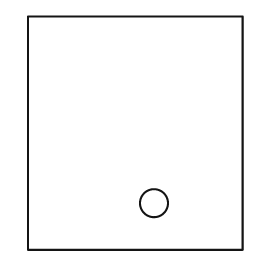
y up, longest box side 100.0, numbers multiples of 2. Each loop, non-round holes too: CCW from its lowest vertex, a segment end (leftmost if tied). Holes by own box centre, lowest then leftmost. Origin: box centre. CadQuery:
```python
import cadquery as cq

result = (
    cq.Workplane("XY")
    .moveTo(-46.0, -50.0)
    .lineTo(46.0, -50.0)
    .lineTo(46.0, 50.0)
    .lineTo(-46.0, 50.0)
    .close()
    .moveTo(8.0, -30.0)
    .circle(6.0)
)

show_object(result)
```